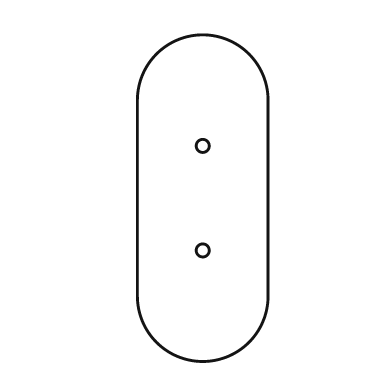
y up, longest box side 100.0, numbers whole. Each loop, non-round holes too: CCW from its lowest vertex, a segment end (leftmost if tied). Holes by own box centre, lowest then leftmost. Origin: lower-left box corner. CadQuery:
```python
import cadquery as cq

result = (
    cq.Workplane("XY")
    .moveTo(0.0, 20.0)
    .threePointArc((20.0, 0.0), (40.0, 20.0))
    .lineTo(40.0, 80.0)
    .threePointArc((20.0, 100.0), (0.0, 80.0))
    .close()
    .moveTo(20.0, 34.0)
    .circle(2.0)
    .moveTo(20.0, 66.0)
    .circle(2.0)
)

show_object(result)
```